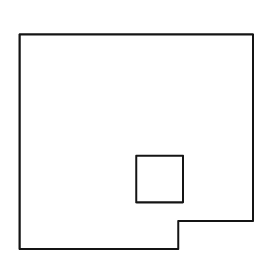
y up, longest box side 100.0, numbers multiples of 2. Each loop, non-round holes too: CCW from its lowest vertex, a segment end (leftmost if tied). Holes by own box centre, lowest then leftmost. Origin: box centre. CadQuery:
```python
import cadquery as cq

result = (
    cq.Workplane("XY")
    .moveTo(-50.0, -46.0)
    .lineTo(18.0, -46.0)
    .lineTo(18.0, -34.0)
    .lineTo(50.0, -34.0)
    .lineTo(50.0, 46.0)
    .lineTo(-50.0, 46.0)
    .close()
    .moveTo(0.0, -26.0)
    .lineTo(20.0, -26.0)
    .lineTo(20.0, -6.0)
    .lineTo(0.0, -6.0)
    .close()
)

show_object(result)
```